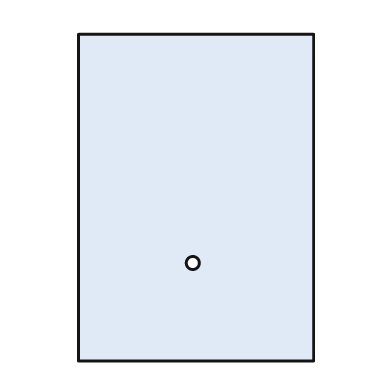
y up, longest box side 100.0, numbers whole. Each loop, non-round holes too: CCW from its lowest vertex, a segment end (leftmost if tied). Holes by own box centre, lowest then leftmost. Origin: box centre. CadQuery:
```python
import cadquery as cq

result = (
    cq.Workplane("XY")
    .moveTo(-36.0, -50.0)
    .lineTo(36.0, -50.0)
    .lineTo(36.0, 50.0)
    .lineTo(-36.0, 50.0)
    .close()
    .moveTo(-1.0, -20.0)
    .circle(2.0)
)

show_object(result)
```